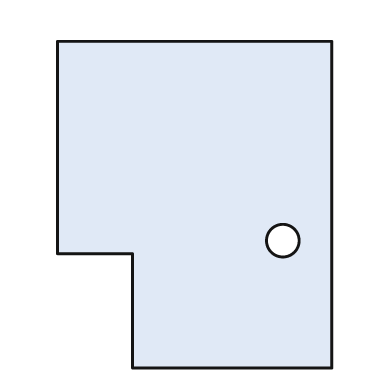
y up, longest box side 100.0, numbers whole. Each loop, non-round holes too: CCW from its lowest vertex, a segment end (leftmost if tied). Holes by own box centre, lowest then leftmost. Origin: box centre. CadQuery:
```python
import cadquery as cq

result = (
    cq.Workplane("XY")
    .moveTo(-19.0, -50.0)
    .lineTo(42.0, -50.0)
    .lineTo(42.0, 50.0)
    .lineTo(-42.0, 50.0)
    .lineTo(-42.0, -15.0)
    .lineTo(-19.0, -15.0)
    .close()
    .moveTo(27.0, -11.0)
    .circle(5.0)
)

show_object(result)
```